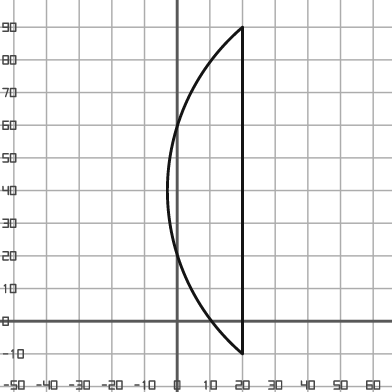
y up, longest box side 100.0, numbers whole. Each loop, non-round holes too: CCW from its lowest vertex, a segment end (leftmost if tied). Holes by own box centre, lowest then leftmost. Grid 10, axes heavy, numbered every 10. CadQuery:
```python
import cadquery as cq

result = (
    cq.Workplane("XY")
    .moveTo(20.0, -10.0)
    .lineTo(20.0, 90.0)
    .threePointArc((-3.0, 40.0), (20.0, -10.0))
    .close()
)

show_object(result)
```